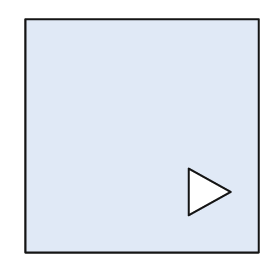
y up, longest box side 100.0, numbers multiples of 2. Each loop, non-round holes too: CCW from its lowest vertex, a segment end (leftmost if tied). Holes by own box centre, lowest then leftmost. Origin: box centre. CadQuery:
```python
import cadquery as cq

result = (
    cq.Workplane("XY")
    .moveTo(-50.0, -50.0)
    .lineTo(50.0, -50.0)
    .lineTo(50.0, 50.0)
    .lineTo(-50.0, 50.0)
    .close()
    .moveTo(20.0, -34.0)
    .lineTo(38.0, -24.0)
    .lineTo(20.0, -14.0)
    .close()
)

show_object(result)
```